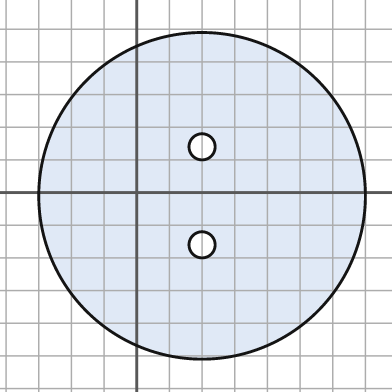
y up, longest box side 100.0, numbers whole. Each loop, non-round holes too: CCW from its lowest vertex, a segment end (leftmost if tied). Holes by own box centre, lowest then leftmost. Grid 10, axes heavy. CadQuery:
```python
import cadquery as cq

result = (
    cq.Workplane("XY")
    .moveTo(20.0, -1.0)
    .circle(50.0)
    .moveTo(20.0, -16.0)
    .circle(4.0)
    .moveTo(20.0, 14.0)
    .circle(4.0)
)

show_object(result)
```